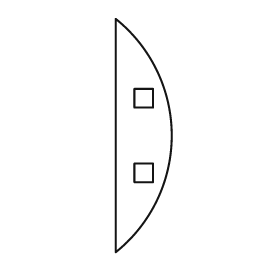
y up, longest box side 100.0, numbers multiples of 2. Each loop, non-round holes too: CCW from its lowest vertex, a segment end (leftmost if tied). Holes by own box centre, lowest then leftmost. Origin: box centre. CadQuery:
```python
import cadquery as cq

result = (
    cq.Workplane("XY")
    .moveTo(-12.0, -50.0)
    .threePointArc((12.0, 0.0), (-12.0, 50.0))
    .close()
    .moveTo(-4.0, -20.0)
    .lineTo(4.0, -20.0)
    .lineTo(4.0, -12.0)
    .lineTo(-4.0, -12.0)
    .close()
    .moveTo(-4.0, 12.0)
    .lineTo(4.0, 12.0)
    .lineTo(4.0, 20.0)
    .lineTo(-4.0, 20.0)
    .close()
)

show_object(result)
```